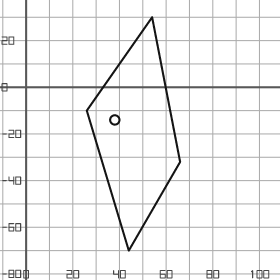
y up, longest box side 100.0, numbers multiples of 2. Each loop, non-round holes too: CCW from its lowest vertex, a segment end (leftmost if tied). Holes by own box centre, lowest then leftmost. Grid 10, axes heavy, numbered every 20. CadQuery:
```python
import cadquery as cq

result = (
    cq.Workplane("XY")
    .moveTo(44.0, -70.0)
    .lineTo(66.0, -32.0)
    .lineTo(54.0, 30.0)
    .lineTo(26.0, -10.0)
    .close()
    .moveTo(38.0, -14.0)
    .circle(2.0)
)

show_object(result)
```